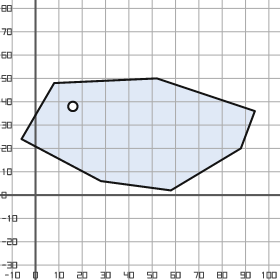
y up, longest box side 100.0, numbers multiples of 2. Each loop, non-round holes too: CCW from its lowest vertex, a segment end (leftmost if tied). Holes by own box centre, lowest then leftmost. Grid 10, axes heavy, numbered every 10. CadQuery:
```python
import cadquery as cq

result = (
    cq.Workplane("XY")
    .moveTo(58.0, 2.0)
    .lineTo(88.0, 20.0)
    .lineTo(94.0, 36.0)
    .lineTo(52.0, 50.0)
    .lineTo(8.0, 48.0)
    .lineTo(-6.0, 24.0)
    .lineTo(28.0, 6.0)
    .close()
    .moveTo(16.0, 38.0)
    .circle(2.0)
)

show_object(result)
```